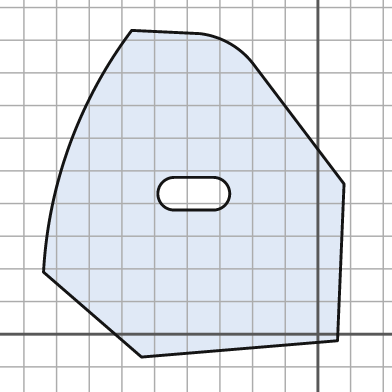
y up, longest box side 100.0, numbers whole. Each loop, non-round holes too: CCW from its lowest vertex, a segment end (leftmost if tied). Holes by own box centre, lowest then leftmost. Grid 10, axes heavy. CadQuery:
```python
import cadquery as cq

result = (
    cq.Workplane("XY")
    .moveTo(-54.0, -7.0)
    .lineTo(6.0, -2.0)
    .lineTo(8.0, 46.0)
    .lineTo(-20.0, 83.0)
    .threePointArc((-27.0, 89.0), (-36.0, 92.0))
    .lineTo(-57.0, 93.0)
    .threePointArc((-76.0, 58.0), (-84.0, 19.0))
    .close()
    .moveTo(-44.0, 38.0)
    .lineTo(-32.0, 38.0)
    .threePointArc((-27.0, 43.0), (-32.0, 48.0))
    .lineTo(-44.0, 48.0)
    .threePointArc((-49.0, 43.0), (-44.0, 38.0))
    .close()
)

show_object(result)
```